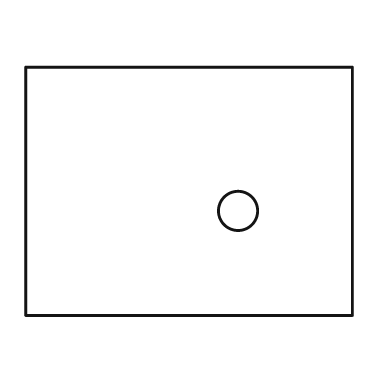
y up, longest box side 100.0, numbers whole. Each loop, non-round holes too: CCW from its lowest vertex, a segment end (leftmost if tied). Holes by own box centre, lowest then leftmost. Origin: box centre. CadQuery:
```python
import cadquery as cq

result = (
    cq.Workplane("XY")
    .moveTo(-50.0, -38.0)
    .lineTo(50.0, -38.0)
    .lineTo(50.0, 38.0)
    .lineTo(-50.0, 38.0)
    .close()
    .moveTo(15.0, -6.0)
    .circle(6.0)
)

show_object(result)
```